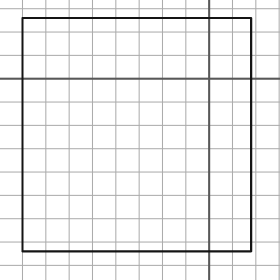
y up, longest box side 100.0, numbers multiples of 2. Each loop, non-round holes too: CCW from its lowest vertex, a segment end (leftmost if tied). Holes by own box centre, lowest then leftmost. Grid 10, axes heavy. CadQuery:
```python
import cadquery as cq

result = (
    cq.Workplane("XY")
    .moveTo(-80.0, -74.0)
    .lineTo(18.0, -74.0)
    .lineTo(18.0, 26.0)
    .lineTo(-80.0, 26.0)
    .close()
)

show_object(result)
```